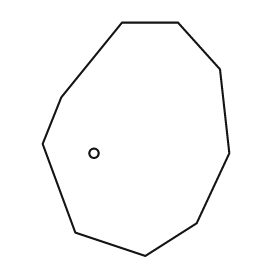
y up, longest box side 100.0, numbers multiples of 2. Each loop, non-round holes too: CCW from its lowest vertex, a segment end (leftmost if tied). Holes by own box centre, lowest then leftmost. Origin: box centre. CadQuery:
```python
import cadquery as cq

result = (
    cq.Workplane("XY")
    .moveTo(4.0, -50.0)
    .lineTo(26.0, -36.0)
    .lineTo(40.0, -6.0)
    .lineTo(36.0, 30.0)
    .lineTo(18.0, 50.0)
    .lineTo(-6.0, 50.0)
    .lineTo(-32.0, 18.0)
    .lineTo(-40.0, -2.0)
    .lineTo(-26.0, -40.0)
    .close()
    .moveTo(-18.0, -6.0)
    .circle(2.0)
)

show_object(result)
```